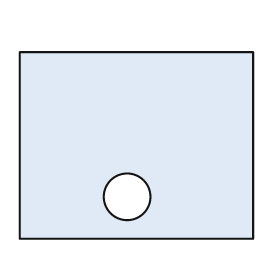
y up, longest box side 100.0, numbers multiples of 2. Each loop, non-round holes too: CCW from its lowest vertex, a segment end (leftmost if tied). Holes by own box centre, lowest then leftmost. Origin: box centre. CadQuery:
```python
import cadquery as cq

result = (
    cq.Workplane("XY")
    .moveTo(-50.0, -40.0)
    .lineTo(50.0, -40.0)
    .lineTo(50.0, 40.0)
    .lineTo(-50.0, 40.0)
    .close()
    .moveTo(-4.0, -22.0)
    .circle(10.0)
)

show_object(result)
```